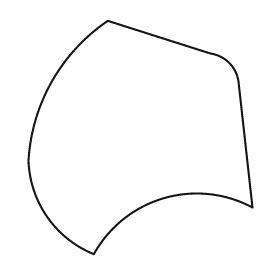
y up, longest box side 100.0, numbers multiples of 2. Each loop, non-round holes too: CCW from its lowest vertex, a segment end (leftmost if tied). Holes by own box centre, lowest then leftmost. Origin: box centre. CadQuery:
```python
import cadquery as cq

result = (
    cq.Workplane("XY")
    .moveTo(-20.0, -50.0)
    .threePointArc((10.0, -26.0), (48.0, -30.0))
    .lineTo(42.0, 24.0)
    .threePointArc((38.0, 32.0), (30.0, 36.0))
    .lineTo(-14.0, 50.0)
    .threePointArc((-38.0, 24.0), (-48.0, -10.0))
    .threePointArc((-40.0, -34.0), (-20.0, -50.0))
    .close()
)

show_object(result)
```